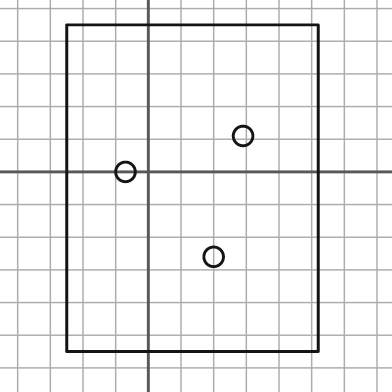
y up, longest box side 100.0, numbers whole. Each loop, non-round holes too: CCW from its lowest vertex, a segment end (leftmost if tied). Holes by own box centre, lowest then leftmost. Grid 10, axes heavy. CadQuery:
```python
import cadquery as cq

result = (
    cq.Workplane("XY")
    .moveTo(-25.0, -55.0)
    .lineTo(52.0, -55.0)
    .lineTo(52.0, 45.0)
    .lineTo(-25.0, 45.0)
    .close()
    .moveTo(20.0, -26.0)
    .circle(3.0)
    .moveTo(-7.0, 0.0)
    .circle(3.0)
    .moveTo(29.0, 11.0)
    .circle(3.0)
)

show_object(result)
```